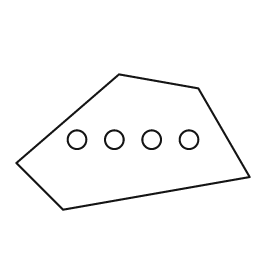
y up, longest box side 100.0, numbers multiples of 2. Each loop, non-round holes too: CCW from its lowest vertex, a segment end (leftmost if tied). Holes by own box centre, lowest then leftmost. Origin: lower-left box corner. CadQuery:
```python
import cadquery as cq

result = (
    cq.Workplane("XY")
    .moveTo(20.0, 0.0)
    .lineTo(100.0, 14.0)
    .lineTo(78.0, 52.0)
    .lineTo(44.0, 58.0)
    .lineTo(0.0, 20.0)
    .close()
    .moveTo(26.0, 30.0)
    .circle(4.0)
    .moveTo(42.0, 30.0)
    .circle(4.0)
    .moveTo(58.0, 30.0)
    .circle(4.0)
    .moveTo(74.0, 30.0)
    .circle(4.0)
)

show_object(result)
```